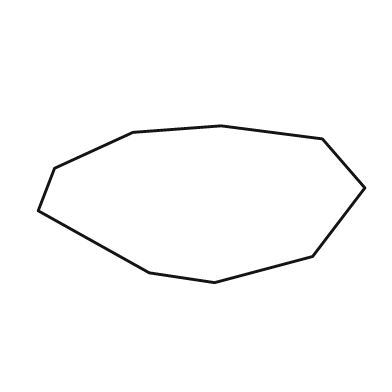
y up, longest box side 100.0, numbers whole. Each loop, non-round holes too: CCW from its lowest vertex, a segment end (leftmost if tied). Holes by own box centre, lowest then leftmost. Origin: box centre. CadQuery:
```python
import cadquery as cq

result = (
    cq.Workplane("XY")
    .moveTo(4.0, -24.0)
    .lineTo(34.0, -16.0)
    .lineTo(50.0, 5.0)
    .lineTo(37.0, 20.0)
    .lineTo(6.0, 24.0)
    .lineTo(-21.0, 22.0)
    .lineTo(-45.0, 11.0)
    .lineTo(-50.0, -2.0)
    .lineTo(-16.0, -21.0)
    .close()
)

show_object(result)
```